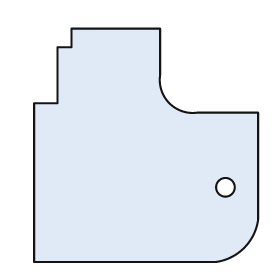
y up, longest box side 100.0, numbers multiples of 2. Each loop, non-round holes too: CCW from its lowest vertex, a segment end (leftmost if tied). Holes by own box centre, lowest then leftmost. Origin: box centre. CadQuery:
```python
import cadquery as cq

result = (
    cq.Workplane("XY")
    .moveTo(-48.0, -50.0)
    .lineTo(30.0, -50.0)
    .threePointArc((42.0, -44.0), (48.0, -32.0))
    .lineTo(48.0, 14.0)
    .lineTo(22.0, 14.0)
    .threePointArc((10.0, 18.0), (6.0, 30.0))
    .lineTo(6.0, 50.0)
    .lineTo(-32.0, 50.0)
    .lineTo(-32.0, 42.0)
    .lineTo(-38.0, 42.0)
    .lineTo(-38.0, 18.0)
    .lineTo(-48.0, 18.0)
    .close()
    .moveTo(34.0, -18.0)
    .circle(4.0)
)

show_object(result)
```